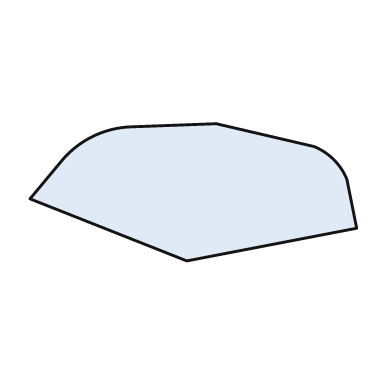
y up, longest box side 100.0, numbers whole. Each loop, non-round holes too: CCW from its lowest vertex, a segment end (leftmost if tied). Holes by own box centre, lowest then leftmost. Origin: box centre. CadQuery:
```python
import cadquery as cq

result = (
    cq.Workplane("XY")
    .moveTo(-2.0, -21.0)
    .lineTo(50.0, -11.0)
    .lineTo(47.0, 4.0)
    .threePointArc((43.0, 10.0), (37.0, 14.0))
    .lineTo(7.0, 21.0)
    .lineTo(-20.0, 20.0)
    .threePointArc((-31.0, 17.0), (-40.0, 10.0))
    .lineTo(-50.0, -2.0)
    .close()
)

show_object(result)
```